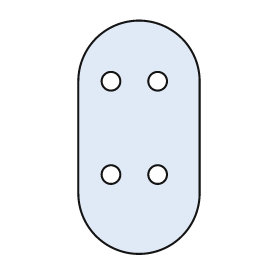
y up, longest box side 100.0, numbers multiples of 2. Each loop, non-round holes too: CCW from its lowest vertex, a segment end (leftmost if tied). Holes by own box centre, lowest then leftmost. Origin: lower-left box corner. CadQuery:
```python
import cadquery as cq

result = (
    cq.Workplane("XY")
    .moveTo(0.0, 26.0)
    .threePointArc((26.0, 0.0), (52.0, 26.0))
    .lineTo(52.0, 74.0)
    .threePointArc((26.0, 100.0), (0.0, 74.0))
    .close()
    .moveTo(14.0, 34.0)
    .circle(4.0)
    .moveTo(34.0, 34.0)
    .circle(4.0)
    .moveTo(14.0, 74.0)
    .circle(4.0)
    .moveTo(34.0, 74.0)
    .circle(4.0)
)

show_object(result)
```